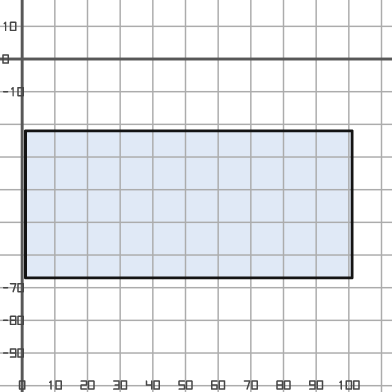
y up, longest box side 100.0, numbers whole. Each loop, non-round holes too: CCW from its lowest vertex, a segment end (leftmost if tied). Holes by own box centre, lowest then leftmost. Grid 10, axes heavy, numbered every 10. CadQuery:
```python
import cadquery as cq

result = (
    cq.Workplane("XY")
    .moveTo(1.0, -67.0)
    .lineTo(101.0, -67.0)
    .lineTo(101.0, -22.0)
    .lineTo(1.0, -22.0)
    .close()
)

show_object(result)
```